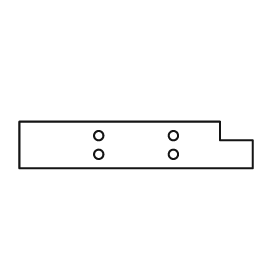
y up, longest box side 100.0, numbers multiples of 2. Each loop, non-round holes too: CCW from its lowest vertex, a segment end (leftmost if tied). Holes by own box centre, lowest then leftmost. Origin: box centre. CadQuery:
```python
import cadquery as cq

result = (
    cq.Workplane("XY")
    .moveTo(-50.0, -10.0)
    .lineTo(50.0, -10.0)
    .lineTo(50.0, 2.0)
    .lineTo(36.0, 2.0)
    .lineTo(36.0, 10.0)
    .lineTo(-50.0, 10.0)
    .close()
    .moveTo(-16.0, -4.0)
    .circle(2.0)
    .moveTo(16.0, -4.0)
    .circle(2.0)
    .moveTo(-16.0, 4.0)
    .circle(2.0)
    .moveTo(16.0, 4.0)
    .circle(2.0)
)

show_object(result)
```